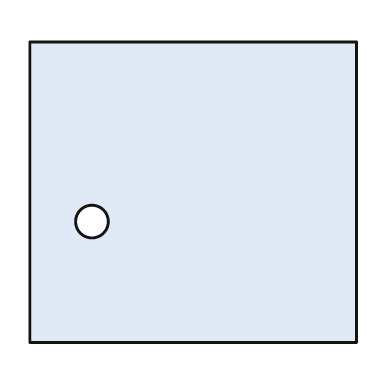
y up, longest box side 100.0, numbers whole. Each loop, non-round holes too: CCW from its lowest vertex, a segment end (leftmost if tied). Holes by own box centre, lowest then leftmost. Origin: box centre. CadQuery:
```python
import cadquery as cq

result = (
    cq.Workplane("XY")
    .moveTo(-50.0, -46.0)
    .lineTo(50.0, -46.0)
    .lineTo(50.0, 46.0)
    .lineTo(-50.0, 46.0)
    .close()
    .moveTo(-31.0, -9.0)
    .circle(5.0)
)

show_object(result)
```